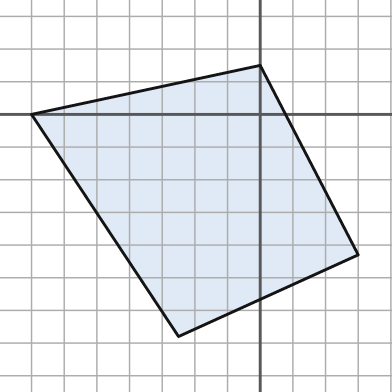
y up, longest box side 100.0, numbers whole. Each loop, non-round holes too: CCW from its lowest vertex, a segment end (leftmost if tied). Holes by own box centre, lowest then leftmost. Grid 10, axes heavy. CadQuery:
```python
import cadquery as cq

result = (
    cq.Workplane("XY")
    .moveTo(-25.0, -68.0)
    .lineTo(30.0, -43.0)
    .lineTo(0.0, 15.0)
    .lineTo(-70.0, 0.0)
    .close()
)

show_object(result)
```